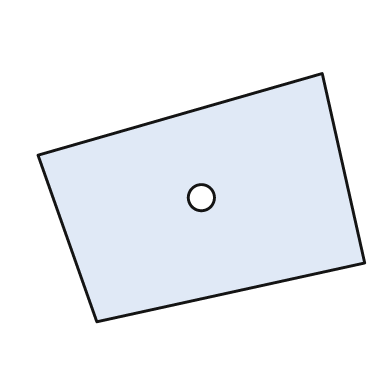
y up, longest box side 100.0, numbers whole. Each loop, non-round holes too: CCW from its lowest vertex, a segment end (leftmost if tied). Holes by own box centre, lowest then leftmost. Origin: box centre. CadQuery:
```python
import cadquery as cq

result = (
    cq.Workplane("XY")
    .moveTo(-32.0, -38.0)
    .lineTo(50.0, -20.0)
    .lineTo(37.0, 38.0)
    .lineTo(-50.0, 13.0)
    .close()
    .moveTo(0.0, 0.0)
    .circle(4.0)
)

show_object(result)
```